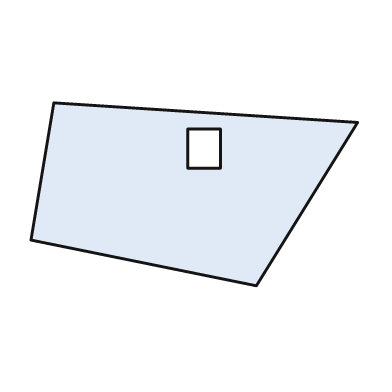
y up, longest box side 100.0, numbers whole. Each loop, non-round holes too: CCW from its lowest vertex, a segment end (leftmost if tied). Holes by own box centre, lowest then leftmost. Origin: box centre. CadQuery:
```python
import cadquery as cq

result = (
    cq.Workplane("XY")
    .moveTo(19.0, -28.0)
    .lineTo(50.0, 22.0)
    .lineTo(-43.0, 28.0)
    .lineTo(-50.0, -14.0)
    .close()
    .moveTo(-2.0, 8.0)
    .lineTo(8.0, 8.0)
    .lineTo(8.0, 20.0)
    .lineTo(-2.0, 20.0)
    .close()
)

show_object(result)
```